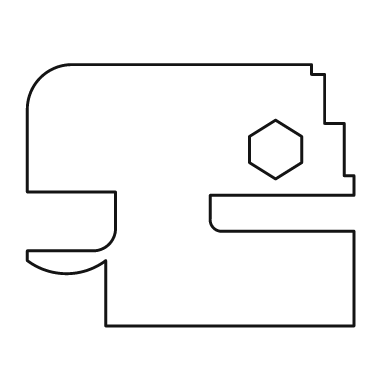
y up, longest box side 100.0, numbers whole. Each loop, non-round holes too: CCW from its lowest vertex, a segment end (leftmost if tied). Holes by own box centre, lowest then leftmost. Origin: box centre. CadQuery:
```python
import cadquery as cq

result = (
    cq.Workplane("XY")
    .moveTo(-26.0, -40.0)
    .lineTo(50.0, -40.0)
    .lineTo(50.0, -11.0)
    .lineTo(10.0, -11.0)
    .threePointArc((7.0, -10.0), (6.0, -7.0))
    .lineTo(6.0, 0.0)
    .lineTo(50.0, 0.0)
    .lineTo(50.0, 6.0)
    .lineTo(47.0, 6.0)
    .lineTo(47.0, 22.0)
    .lineTo(41.0, 22.0)
    .lineTo(41.0, 37.0)
    .lineTo(37.0, 37.0)
    .lineTo(37.0, 40.0)
    .lineTo(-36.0, 40.0)
    .threePointArc((-46.0, 36.0), (-50.0, 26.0))
    .lineTo(-50.0, 1.0)
    .lineTo(-23.0, 1.0)
    .lineTo(-23.0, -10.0)
    .threePointArc((-25.0, -15.0), (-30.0, -17.0))
    .lineTo(-50.0, -17.0)
    .lineTo(-50.0, -20.0)
    .threePointArc((-38.0, -24.0), (-26.0, -20.0))
    .close()
    .moveTo(26.0, 5.0)
    .lineTo(34.0, 10.0)
    .lineTo(34.0, 18.0)
    .lineTo(26.0, 23.0)
    .lineTo(18.0, 18.0)
    .lineTo(18.0, 10.0)
    .close()
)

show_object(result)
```